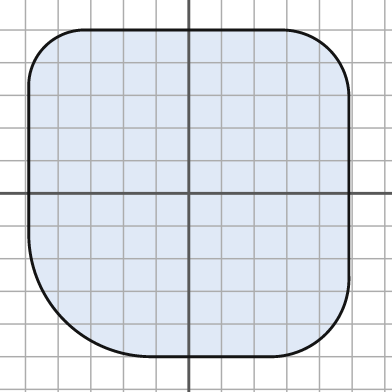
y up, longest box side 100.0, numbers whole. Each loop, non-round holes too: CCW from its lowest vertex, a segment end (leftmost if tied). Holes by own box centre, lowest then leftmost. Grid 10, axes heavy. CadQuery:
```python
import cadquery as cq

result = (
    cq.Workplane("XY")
    .moveTo(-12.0, -50.0)
    .lineTo(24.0, -50.0)
    .threePointArc((42.0, -43.0), (49.0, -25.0))
    .lineTo(49.0, 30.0)
    .threePointArc((43.0, 44.0), (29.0, 50.0))
    .lineTo(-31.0, 50.0)
    .threePointArc((-44.0, 45.0), (-49.0, 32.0))
    .lineTo(-49.0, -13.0)
    .threePointArc((-38.0, -39.0), (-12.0, -50.0))
    .close()
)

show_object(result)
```